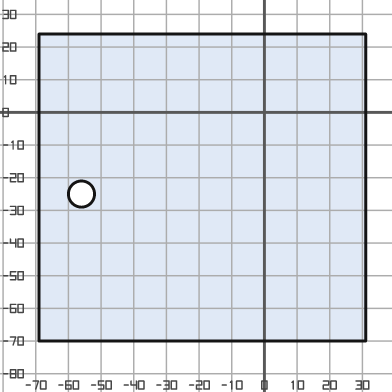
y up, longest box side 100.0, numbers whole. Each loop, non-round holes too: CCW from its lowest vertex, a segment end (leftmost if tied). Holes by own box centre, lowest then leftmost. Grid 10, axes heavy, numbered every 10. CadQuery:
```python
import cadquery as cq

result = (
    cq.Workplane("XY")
    .moveTo(-69.0, -70.0)
    .lineTo(31.0, -70.0)
    .lineTo(31.0, 24.0)
    .lineTo(-69.0, 24.0)
    .close()
    .moveTo(-56.0, -25.0)
    .circle(4.0)
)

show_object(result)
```